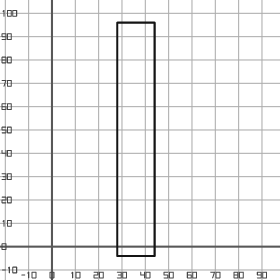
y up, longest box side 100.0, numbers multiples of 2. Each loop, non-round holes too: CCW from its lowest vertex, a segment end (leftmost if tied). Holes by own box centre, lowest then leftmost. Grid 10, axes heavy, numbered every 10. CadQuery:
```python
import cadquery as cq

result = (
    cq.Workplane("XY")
    .moveTo(28.0, -4.0)
    .lineTo(44.0, -4.0)
    .lineTo(44.0, 96.0)
    .lineTo(28.0, 96.0)
    .close()
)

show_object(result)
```